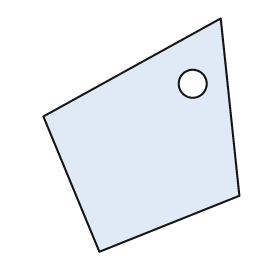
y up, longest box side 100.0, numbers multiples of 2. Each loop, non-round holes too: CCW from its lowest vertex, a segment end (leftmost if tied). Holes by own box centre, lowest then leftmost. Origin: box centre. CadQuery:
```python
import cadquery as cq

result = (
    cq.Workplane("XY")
    .moveTo(-18.0, -50.0)
    .lineTo(42.0, -26.0)
    .lineTo(34.0, 50.0)
    .lineTo(-42.0, 8.0)
    .close()
    .moveTo(22.0, 22.0)
    .circle(6.0)
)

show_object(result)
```